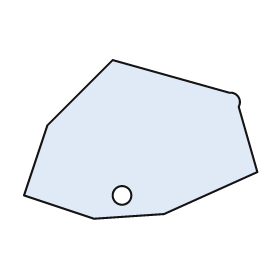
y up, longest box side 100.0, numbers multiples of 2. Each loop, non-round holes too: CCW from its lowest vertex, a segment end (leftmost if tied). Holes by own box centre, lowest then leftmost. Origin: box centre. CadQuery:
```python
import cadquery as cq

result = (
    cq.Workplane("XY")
    .moveTo(-20.0, -34.0)
    .lineTo(10.0, -32.0)
    .lineTo(50.0, -14.0)
    .lineTo(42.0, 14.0)
    .threePointArc((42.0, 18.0), (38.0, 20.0))
    .lineTo(-12.0, 34.0)
    .lineTo(-40.0, 6.0)
    .lineTo(-50.0, -24.0)
    .close()
    .moveTo(-8.0, -24.0)
    .circle(4.0)
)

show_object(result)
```